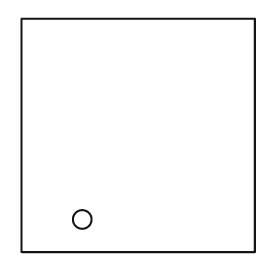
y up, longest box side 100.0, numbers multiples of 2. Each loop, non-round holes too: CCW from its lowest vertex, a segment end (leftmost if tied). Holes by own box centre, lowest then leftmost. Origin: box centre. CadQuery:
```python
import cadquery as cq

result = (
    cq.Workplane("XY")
    .moveTo(-50.0, -50.0)
    .lineTo(50.0, -50.0)
    .lineTo(50.0, 50.0)
    .lineTo(-50.0, 50.0)
    .close()
    .moveTo(-24.0, -36.0)
    .circle(4.0)
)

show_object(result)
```